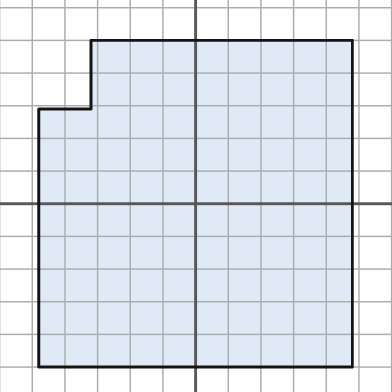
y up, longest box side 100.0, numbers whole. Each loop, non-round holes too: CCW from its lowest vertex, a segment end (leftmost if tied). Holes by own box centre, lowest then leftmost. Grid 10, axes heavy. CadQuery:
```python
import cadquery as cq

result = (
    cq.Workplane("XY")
    .moveTo(-48.0, -50.0)
    .lineTo(48.0, -50.0)
    .lineTo(48.0, 50.0)
    .lineTo(-32.0, 50.0)
    .lineTo(-32.0, 29.0)
    .lineTo(-48.0, 29.0)
    .close()
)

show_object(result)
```